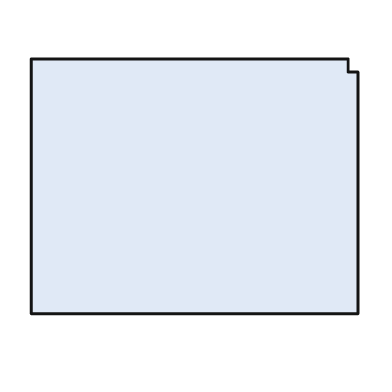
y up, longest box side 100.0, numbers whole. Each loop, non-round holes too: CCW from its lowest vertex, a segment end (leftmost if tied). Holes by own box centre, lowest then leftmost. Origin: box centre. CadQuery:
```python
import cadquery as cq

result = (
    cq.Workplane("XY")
    .moveTo(-50.0, -39.0)
    .lineTo(50.0, -39.0)
    .lineTo(50.0, 35.0)
    .lineTo(47.0, 35.0)
    .lineTo(47.0, 39.0)
    .lineTo(-50.0, 39.0)
    .close()
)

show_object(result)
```